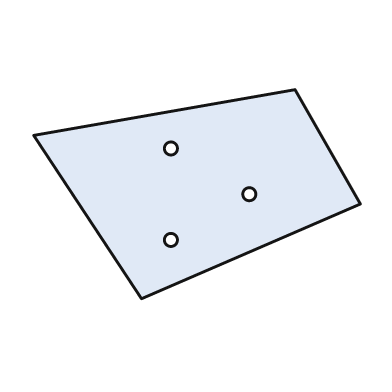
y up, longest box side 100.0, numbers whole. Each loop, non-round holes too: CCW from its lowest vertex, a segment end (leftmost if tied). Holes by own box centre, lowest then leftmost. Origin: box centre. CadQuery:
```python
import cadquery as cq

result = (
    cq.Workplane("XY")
    .moveTo(-17.0, -32.0)
    .lineTo(50.0, -3.0)
    .lineTo(30.0, 32.0)
    .lineTo(-50.0, 18.0)
    .close()
    .moveTo(-8.0, -14.0)
    .circle(2.0)
    .moveTo(16.0, 0.0)
    .circle(2.0)
    .moveTo(-8.0, 14.0)
    .circle(2.0)
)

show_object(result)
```